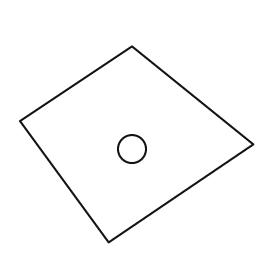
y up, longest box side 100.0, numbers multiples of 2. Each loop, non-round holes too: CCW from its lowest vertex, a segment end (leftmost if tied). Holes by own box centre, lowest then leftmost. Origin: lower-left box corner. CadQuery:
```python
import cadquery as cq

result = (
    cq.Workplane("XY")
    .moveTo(38.0, 0.0)
    .lineTo(100.0, 42.0)
    .lineTo(48.0, 84.0)
    .lineTo(0.0, 52.0)
    .close()
    .moveTo(48.0, 40.0)
    .circle(6.0)
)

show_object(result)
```